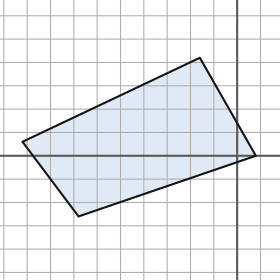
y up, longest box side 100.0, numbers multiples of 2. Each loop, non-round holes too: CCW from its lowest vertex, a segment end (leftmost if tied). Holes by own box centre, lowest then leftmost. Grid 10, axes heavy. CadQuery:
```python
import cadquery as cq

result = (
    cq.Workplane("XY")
    .moveTo(-68.0, -26.0)
    .lineTo(8.0, 0.0)
    .lineTo(-16.0, 42.0)
    .lineTo(-92.0, 6.0)
    .close()
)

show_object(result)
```